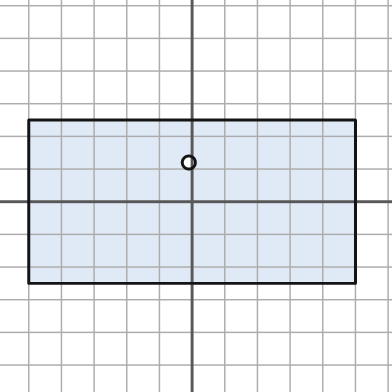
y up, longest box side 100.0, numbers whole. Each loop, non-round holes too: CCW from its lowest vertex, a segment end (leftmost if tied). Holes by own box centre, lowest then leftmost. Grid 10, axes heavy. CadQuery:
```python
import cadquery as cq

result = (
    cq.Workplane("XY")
    .moveTo(-50.0, -25.0)
    .lineTo(50.0, -25.0)
    .lineTo(50.0, 25.0)
    .lineTo(-50.0, 25.0)
    .close()
    .moveTo(-1.0, 12.0)
    .circle(2.0)
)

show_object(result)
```